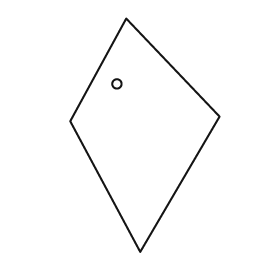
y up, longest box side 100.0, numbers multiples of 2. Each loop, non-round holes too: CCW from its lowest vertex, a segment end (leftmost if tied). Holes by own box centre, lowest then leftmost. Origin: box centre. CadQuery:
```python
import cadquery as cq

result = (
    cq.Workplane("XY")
    .moveTo(-2.0, -50.0)
    .lineTo(32.0, 8.0)
    .lineTo(-8.0, 50.0)
    .lineTo(-32.0, 6.0)
    .close()
    .moveTo(-12.0, 22.0)
    .circle(2.0)
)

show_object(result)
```